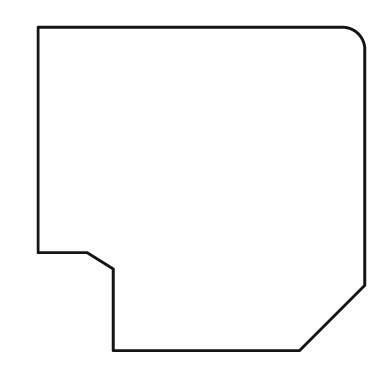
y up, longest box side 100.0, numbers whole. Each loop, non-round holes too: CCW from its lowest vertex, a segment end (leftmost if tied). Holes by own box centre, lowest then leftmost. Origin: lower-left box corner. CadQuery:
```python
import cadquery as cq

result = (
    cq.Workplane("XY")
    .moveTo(23.0, 0.0)
    .lineTo(80.0, 0.0)
    .lineTo(100.0, 20.0)
    .lineTo(100.0, 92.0)
    .threePointArc((98.0, 97.0), (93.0, 99.0))
    .lineTo(0.0, 99.0)
    .lineTo(0.0, 30.0)
    .lineTo(15.0, 30.0)
    .lineTo(23.0, 25.0)
    .close()
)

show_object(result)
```